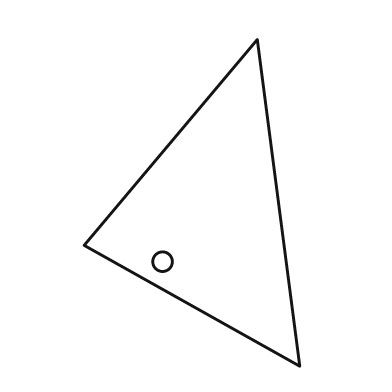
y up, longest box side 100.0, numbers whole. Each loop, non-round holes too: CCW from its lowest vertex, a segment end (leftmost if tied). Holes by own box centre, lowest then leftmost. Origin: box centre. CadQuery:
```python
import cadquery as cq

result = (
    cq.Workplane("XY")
    .moveTo(33.0, -50.0)
    .lineTo(20.0, 50.0)
    .lineTo(-33.0, -13.0)
    .close()
    .moveTo(-9.0, -18.0)
    .circle(3.0)
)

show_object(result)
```